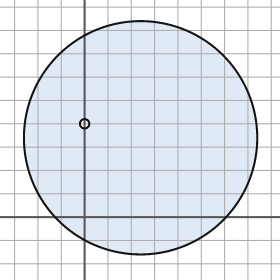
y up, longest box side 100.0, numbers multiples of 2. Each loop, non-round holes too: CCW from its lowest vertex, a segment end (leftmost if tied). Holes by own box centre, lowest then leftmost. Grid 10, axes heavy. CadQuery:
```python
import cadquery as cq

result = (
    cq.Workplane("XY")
    .moveTo(24.0, 34.0)
    .circle(50.0)
    .moveTo(0.0, 40.0)
    .circle(2.0)
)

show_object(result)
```